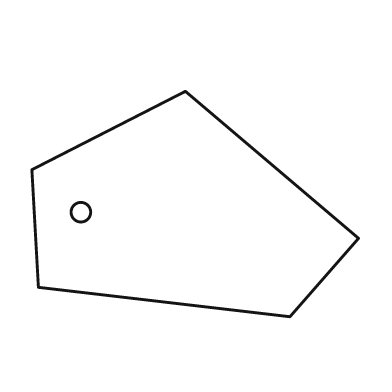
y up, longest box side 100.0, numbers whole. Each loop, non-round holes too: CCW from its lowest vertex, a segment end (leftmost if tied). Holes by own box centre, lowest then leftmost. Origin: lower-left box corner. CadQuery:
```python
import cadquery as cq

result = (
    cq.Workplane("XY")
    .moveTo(79.0, 0.0)
    .lineTo(100.0, 24.0)
    .lineTo(47.0, 69.0)
    .lineTo(0.0, 45.0)
    .lineTo(2.0, 9.0)
    .close()
    .moveTo(15.0, 32.0)
    .circle(3.0)
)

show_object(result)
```